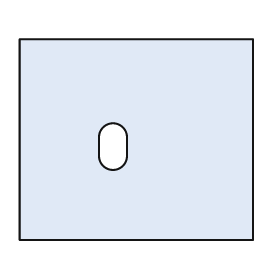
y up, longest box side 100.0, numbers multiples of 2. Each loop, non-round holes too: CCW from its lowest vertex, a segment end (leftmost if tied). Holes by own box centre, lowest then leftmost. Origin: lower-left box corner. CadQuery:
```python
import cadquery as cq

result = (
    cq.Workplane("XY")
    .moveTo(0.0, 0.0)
    .lineTo(100.0, 0.0)
    .lineTo(100.0, 86.0)
    .lineTo(0.0, 86.0)
    .close()
    .moveTo(34.0, 36.0)
    .threePointArc((40.0, 30.0), (46.0, 36.0))
    .lineTo(46.0, 44.0)
    .threePointArc((40.0, 50.0), (34.0, 44.0))
    .close()
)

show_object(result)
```